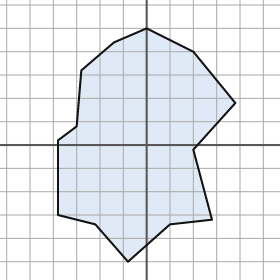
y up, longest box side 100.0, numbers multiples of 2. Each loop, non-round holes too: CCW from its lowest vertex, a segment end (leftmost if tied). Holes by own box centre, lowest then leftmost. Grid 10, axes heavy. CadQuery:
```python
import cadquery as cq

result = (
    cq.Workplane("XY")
    .moveTo(-8.0, -50.0)
    .lineTo(10.0, -34.0)
    .lineTo(28.0, -32.0)
    .lineTo(20.0, -2.0)
    .lineTo(38.0, 18.0)
    .lineTo(20.0, 40.0)
    .lineTo(0.0, 50.0)
    .lineTo(-14.0, 44.0)
    .lineTo(-28.0, 32.0)
    .lineTo(-30.0, 8.0)
    .lineTo(-38.0, 2.0)
    .lineTo(-38.0, -30.0)
    .lineTo(-22.0, -34.0)
    .close()
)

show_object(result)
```